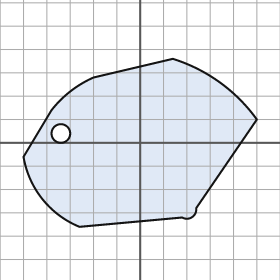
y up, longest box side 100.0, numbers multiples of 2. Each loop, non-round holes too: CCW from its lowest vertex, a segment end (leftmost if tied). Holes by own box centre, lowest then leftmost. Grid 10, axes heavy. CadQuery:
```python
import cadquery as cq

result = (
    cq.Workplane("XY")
    .moveTo(-26.0, -36.0)
    .lineTo(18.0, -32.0)
    .threePointArc((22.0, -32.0), (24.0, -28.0))
    .lineTo(50.0, 10.0)
    .threePointArc((34.0, 26.0), (14.0, 36.0))
    .lineTo(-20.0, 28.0)
    .threePointArc((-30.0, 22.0), (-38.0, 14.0))
    .lineTo(-50.0, -6.0)
    .threePointArc((-42.0, -24.0), (-26.0, -36.0))
    .close()
    .moveTo(-34.0, 4.0)
    .circle(4.0)
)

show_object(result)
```